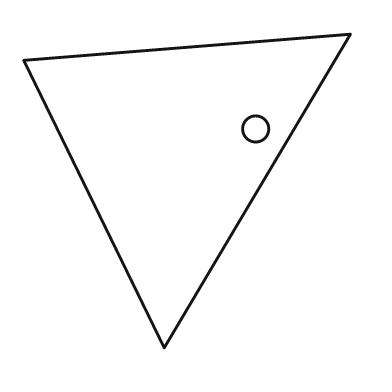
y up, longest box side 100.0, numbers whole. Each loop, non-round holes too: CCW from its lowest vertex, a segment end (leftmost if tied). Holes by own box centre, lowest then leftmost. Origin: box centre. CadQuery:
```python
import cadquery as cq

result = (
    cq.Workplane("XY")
    .moveTo(-7.0, -48.0)
    .lineTo(50.0, 48.0)
    .lineTo(-50.0, 40.0)
    .close()
    .moveTo(21.0, 19.0)
    .circle(4.0)
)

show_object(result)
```